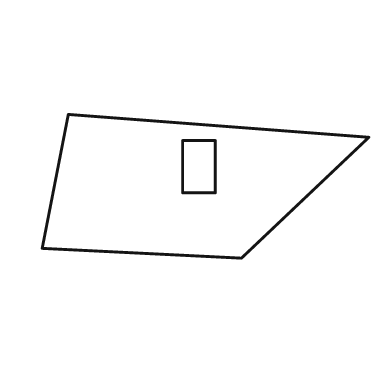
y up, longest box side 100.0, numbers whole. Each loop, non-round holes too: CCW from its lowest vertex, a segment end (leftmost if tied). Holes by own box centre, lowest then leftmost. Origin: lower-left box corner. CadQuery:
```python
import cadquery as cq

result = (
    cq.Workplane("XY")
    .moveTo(61.0, 0.0)
    .lineTo(100.0, 37.0)
    .lineTo(8.0, 44.0)
    .lineTo(0.0, 3.0)
    .close()
    .moveTo(43.0, 20.0)
    .lineTo(53.0, 20.0)
    .lineTo(53.0, 36.0)
    .lineTo(43.0, 36.0)
    .close()
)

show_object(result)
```